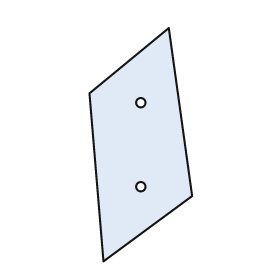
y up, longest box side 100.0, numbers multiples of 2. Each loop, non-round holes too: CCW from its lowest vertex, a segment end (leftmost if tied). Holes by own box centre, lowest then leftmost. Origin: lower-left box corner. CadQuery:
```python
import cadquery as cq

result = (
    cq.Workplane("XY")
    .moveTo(6.0, 0.0)
    .lineTo(44.0, 28.0)
    .lineTo(34.0, 100.0)
    .lineTo(0.0, 72.0)
    .close()
    .moveTo(22.0, 32.0)
    .circle(2.0)
    .moveTo(22.0, 68.0)
    .circle(2.0)
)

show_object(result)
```